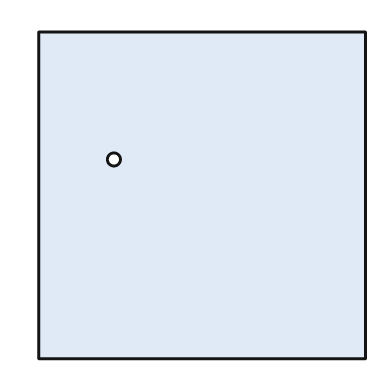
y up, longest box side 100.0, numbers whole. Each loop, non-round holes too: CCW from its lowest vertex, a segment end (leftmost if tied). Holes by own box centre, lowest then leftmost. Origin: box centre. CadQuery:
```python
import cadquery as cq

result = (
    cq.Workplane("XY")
    .moveTo(-50.0, -50.0)
    .lineTo(50.0, -50.0)
    .lineTo(50.0, 50.0)
    .lineTo(-50.0, 50.0)
    .close()
    .moveTo(-27.0, 11.0)
    .circle(2.0)
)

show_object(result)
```